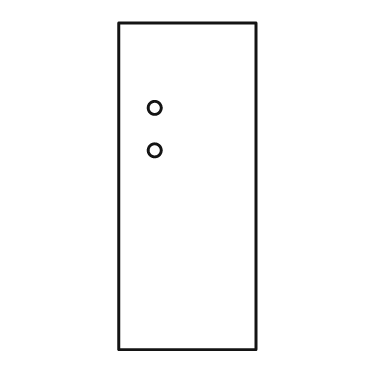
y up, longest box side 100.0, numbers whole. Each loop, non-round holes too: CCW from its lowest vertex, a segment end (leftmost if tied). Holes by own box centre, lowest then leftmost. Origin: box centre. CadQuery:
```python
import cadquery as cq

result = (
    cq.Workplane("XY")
    .moveTo(-21.0, -50.0)
    .lineTo(21.0, -50.0)
    .lineTo(21.0, 50.0)
    .lineTo(-21.0, 50.0)
    .close()
    .moveTo(-10.0, 11.0)
    .circle(2.0)
    .moveTo(-10.0, 24.0)
    .circle(2.0)
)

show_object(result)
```